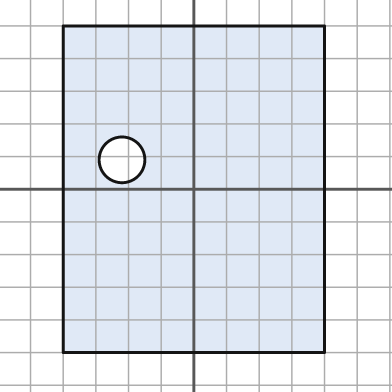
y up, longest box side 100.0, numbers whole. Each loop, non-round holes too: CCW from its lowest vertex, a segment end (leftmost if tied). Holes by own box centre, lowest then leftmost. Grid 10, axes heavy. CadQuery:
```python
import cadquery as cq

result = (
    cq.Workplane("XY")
    .moveTo(-40.0, -50.0)
    .lineTo(40.0, -50.0)
    .lineTo(40.0, 50.0)
    .lineTo(-40.0, 50.0)
    .close()
    .moveTo(-22.0, 9.0)
    .circle(7.0)
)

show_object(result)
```